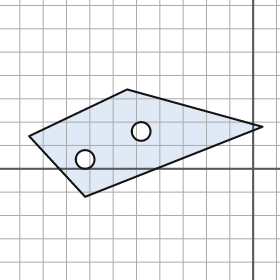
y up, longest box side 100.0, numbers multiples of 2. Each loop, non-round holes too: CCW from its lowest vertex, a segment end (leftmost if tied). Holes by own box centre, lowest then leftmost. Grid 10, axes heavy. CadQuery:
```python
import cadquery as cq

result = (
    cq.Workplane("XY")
    .moveTo(-72.0, -12.0)
    .lineTo(4.0, 18.0)
    .lineTo(-54.0, 34.0)
    .lineTo(-96.0, 14.0)
    .close()
    .moveTo(-72.0, 4.0)
    .circle(4.0)
    .moveTo(-48.0, 16.0)
    .circle(4.0)
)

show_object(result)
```